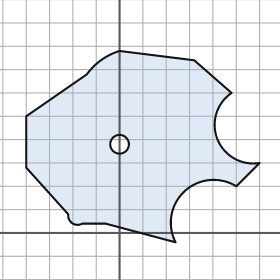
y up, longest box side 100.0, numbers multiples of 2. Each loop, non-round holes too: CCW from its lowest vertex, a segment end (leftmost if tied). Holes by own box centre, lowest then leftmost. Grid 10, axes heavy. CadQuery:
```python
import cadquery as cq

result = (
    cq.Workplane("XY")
    .moveTo(24.0, -4.0)
    .threePointArc((28.0, 18.0), (50.0, 20.0))
    .lineTo(60.0, 30.0)
    .threePointArc((42.0, 40.0), (48.0, 60.0))
    .lineTo(32.0, 74.0)
    .lineTo(0.0, 78.0)
    .threePointArc((-8.0, 74.0), (-14.0, 68.0))
    .lineTo(-40.0, 50.0)
    .lineTo(-40.0, 28.0)
    .lineTo(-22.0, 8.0)
    .threePointArc((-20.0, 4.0), (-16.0, 4.0))
    .lineTo(-6.0, 4.0)
    .close()
    .moveTo(0.0, 38.0)
    .circle(4.0)
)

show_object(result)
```